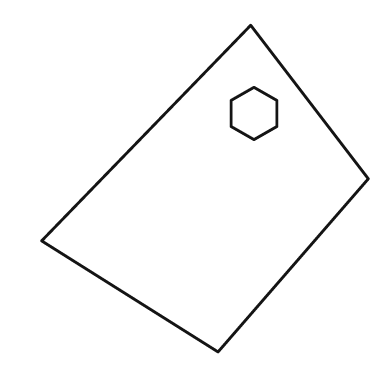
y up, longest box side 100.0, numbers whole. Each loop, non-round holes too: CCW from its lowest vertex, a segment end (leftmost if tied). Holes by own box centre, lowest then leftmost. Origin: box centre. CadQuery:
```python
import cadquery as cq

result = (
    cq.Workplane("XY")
    .moveTo(4.0, -50.0)
    .lineTo(50.0, 3.0)
    .lineTo(14.0, 50.0)
    .lineTo(-50.0, -16.0)
    .close()
    .moveTo(15.0, 15.0)
    .lineTo(22.0, 19.0)
    .lineTo(22.0, 27.0)
    .lineTo(15.0, 31.0)
    .lineTo(8.0, 27.0)
    .lineTo(8.0, 19.0)
    .close()
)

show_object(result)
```